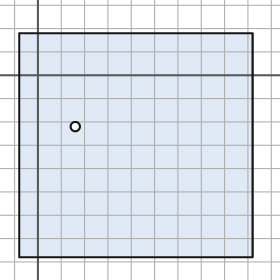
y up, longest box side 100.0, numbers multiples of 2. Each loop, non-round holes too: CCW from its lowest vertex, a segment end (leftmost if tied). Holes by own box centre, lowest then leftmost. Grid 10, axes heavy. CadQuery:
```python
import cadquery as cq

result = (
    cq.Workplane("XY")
    .moveTo(-8.0, -78.0)
    .lineTo(92.0, -78.0)
    .lineTo(92.0, 18.0)
    .lineTo(-8.0, 18.0)
    .close()
    .moveTo(16.0, -22.0)
    .circle(2.0)
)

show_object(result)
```